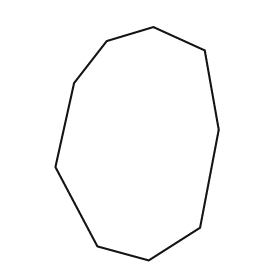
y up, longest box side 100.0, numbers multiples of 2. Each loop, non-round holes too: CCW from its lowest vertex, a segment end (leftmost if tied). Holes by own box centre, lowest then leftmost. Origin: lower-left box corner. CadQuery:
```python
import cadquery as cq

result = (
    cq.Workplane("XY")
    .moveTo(40.0, 0.0)
    .lineTo(62.0, 14.0)
    .lineTo(70.0, 56.0)
    .lineTo(64.0, 90.0)
    .lineTo(42.0, 100.0)
    .lineTo(22.0, 94.0)
    .lineTo(8.0, 76.0)
    .lineTo(0.0, 40.0)
    .lineTo(18.0, 6.0)
    .close()
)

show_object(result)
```